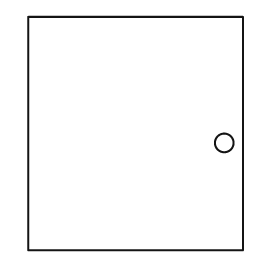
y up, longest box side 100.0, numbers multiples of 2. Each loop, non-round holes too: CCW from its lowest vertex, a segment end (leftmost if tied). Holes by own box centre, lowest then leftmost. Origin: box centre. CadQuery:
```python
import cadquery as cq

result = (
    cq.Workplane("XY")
    .moveTo(-46.0, -50.0)
    .lineTo(46.0, -50.0)
    .lineTo(46.0, 50.0)
    .lineTo(-46.0, 50.0)
    .close()
    .moveTo(38.0, -4.0)
    .circle(4.0)
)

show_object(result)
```